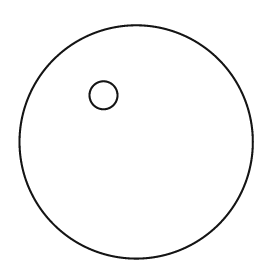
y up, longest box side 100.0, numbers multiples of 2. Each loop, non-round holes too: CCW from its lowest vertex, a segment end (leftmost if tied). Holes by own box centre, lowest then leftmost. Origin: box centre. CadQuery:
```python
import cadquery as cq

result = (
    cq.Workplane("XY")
    .moveTo(0.0, 0.0)
    .circle(50.0)
    .moveTo(-14.0, 20.0)
    .circle(6.0)
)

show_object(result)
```